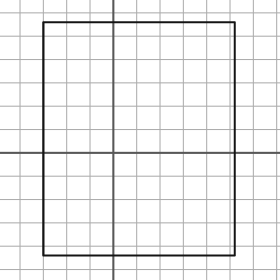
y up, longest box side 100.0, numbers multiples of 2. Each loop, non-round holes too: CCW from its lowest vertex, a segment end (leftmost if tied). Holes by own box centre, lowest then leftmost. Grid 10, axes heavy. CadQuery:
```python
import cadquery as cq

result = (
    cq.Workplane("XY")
    .moveTo(-30.0, -44.0)
    .lineTo(52.0, -44.0)
    .lineTo(52.0, 56.0)
    .lineTo(-30.0, 56.0)
    .close()
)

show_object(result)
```